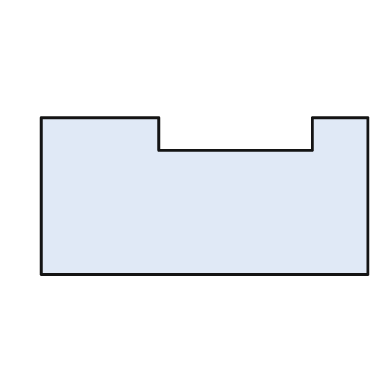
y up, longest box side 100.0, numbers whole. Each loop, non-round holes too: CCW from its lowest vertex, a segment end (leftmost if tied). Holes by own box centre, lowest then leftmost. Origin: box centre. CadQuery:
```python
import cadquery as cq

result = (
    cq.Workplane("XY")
    .moveTo(-50.0, -24.0)
    .lineTo(50.0, -24.0)
    .lineTo(50.0, 24.0)
    .lineTo(33.0, 24.0)
    .lineTo(33.0, 14.0)
    .lineTo(-14.0, 14.0)
    .lineTo(-14.0, 24.0)
    .lineTo(-50.0, 24.0)
    .close()
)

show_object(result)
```